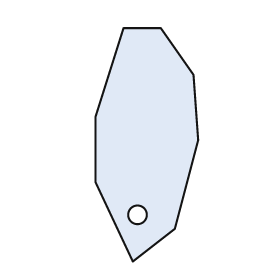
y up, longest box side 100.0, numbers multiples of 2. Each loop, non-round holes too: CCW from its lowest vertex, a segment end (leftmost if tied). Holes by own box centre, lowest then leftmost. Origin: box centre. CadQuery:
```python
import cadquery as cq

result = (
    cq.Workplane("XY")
    .moveTo(-6.0, -50.0)
    .lineTo(12.0, -36.0)
    .lineTo(22.0, 2.0)
    .lineTo(20.0, 30.0)
    .lineTo(6.0, 50.0)
    .lineTo(-10.0, 50.0)
    .lineTo(-22.0, 12.0)
    .lineTo(-22.0, -16.0)
    .close()
    .moveTo(-4.0, -30.0)
    .circle(4.0)
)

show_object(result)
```